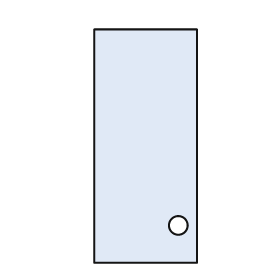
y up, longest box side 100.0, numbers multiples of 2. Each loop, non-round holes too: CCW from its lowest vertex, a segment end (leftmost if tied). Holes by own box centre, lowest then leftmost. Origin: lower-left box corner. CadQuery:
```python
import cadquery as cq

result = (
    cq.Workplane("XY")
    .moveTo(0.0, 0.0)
    .lineTo(44.0, 0.0)
    .lineTo(44.0, 100.0)
    .lineTo(0.0, 100.0)
    .close()
    .moveTo(36.0, 16.0)
    .circle(4.0)
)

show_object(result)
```